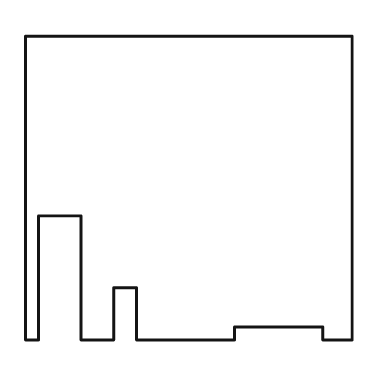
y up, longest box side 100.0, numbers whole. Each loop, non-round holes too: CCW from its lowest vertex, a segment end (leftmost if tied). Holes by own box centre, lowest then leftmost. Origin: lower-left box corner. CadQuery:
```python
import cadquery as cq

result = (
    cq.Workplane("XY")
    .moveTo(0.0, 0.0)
    .lineTo(4.0, 0.0)
    .lineTo(4.0, 38.0)
    .lineTo(17.0, 38.0)
    .lineTo(17.0, 0.0)
    .lineTo(27.0, 0.0)
    .lineTo(27.0, 16.0)
    .lineTo(34.0, 16.0)
    .lineTo(34.0, 0.0)
    .lineTo(64.0, 0.0)
    .lineTo(64.0, 4.0)
    .lineTo(91.0, 4.0)
    .lineTo(91.0, 0.0)
    .lineTo(100.0, 0.0)
    .lineTo(100.0, 93.0)
    .lineTo(0.0, 93.0)
    .close()
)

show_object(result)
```